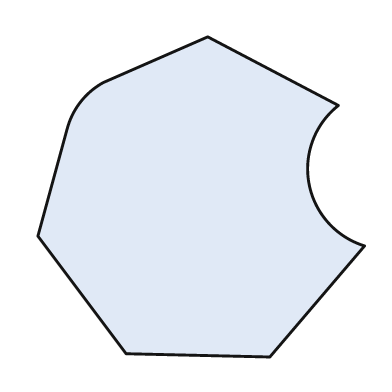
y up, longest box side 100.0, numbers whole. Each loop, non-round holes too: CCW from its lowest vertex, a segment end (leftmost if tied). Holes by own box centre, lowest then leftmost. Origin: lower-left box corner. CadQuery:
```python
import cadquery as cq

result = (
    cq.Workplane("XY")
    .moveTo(71.0, 0.0)
    .lineTo(100.0, 34.0)
    .threePointArc((83.0, 53.0), (92.0, 77.0))
    .lineTo(52.0, 98.0)
    .lineTo(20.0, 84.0)
    .threePointArc((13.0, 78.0), (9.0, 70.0))
    .lineTo(0.0, 37.0)
    .lineTo(27.0, 1.0)
    .close()
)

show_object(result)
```